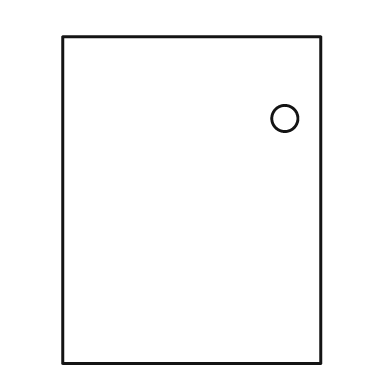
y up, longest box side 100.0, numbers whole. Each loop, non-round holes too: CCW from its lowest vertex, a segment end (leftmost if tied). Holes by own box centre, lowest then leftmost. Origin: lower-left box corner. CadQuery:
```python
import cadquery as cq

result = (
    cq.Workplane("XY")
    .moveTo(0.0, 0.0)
    .lineTo(79.0, 0.0)
    .lineTo(79.0, 100.0)
    .lineTo(0.0, 100.0)
    .close()
    .moveTo(68.0, 75.0)
    .circle(4.0)
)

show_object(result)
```